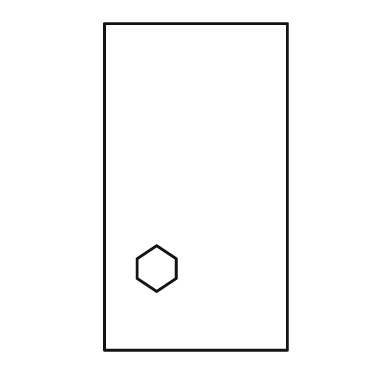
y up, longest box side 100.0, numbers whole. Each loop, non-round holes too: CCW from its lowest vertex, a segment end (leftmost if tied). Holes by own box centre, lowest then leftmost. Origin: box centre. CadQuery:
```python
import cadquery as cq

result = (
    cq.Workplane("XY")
    .moveTo(-28.0, -50.0)
    .lineTo(28.0, -50.0)
    .lineTo(28.0, 50.0)
    .lineTo(-28.0, 50.0)
    .close()
    .moveTo(-12.0, -32.0)
    .lineTo(-6.0, -28.0)
    .lineTo(-6.0, -22.0)
    .lineTo(-12.0, -18.0)
    .lineTo(-18.0, -22.0)
    .lineTo(-18.0, -28.0)
    .close()
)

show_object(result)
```